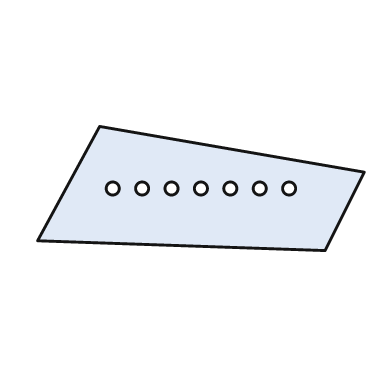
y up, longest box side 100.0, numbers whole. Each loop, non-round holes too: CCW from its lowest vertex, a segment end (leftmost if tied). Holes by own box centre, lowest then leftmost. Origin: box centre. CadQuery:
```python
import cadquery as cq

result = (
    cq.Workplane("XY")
    .moveTo(38.0, -19.0)
    .lineTo(50.0, 5.0)
    .lineTo(-31.0, 19.0)
    .lineTo(-50.0, -16.0)
    .close()
    .moveTo(-27.0, 0.0)
    .circle(2.0)
    .moveTo(-18.0, 0.0)
    .circle(2.0)
    .moveTo(-9.0, 0.0)
    .circle(2.0)
    .moveTo(0.0, 0.0)
    .circle(2.0)
    .moveTo(9.0, 0.0)
    .circle(2.0)
    .moveTo(18.0, 0.0)
    .circle(2.0)
    .moveTo(27.0, 0.0)
    .circle(2.0)
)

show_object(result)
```